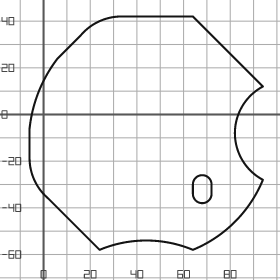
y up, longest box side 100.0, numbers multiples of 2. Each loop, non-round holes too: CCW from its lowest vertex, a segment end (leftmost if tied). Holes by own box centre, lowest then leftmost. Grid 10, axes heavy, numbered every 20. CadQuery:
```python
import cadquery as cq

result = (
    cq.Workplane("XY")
    .moveTo(24.0, -58.0)
    .threePointArc((44.0, -54.0), (64.0, -58.0))
    .threePointArc((82.0, -46.0), (94.0, -28.0))
    .threePointArc((82.0, -8.0), (94.0, 12.0))
    .lineTo(64.0, 42.0)
    .lineTo(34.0, 42.0)
    .threePointArc((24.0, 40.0), (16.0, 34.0))
    .lineTo(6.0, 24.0)
    .threePointArc((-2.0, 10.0), (-6.0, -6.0))
    .lineTo(-6.0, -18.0)
    .threePointArc((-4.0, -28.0), (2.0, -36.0))
    .close()
    .moveTo(64.0, -34.0)
    .threePointArc((68.0, -38.0), (72.0, -34.0))
    .lineTo(72.0, -30.0)
    .threePointArc((68.0, -26.0), (64.0, -30.0))
    .close()
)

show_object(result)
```